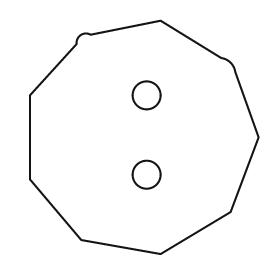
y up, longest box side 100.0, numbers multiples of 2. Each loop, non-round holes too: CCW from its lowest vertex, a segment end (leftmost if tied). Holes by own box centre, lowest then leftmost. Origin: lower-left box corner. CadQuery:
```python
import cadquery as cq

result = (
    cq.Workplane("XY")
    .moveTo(56.0, 0.0)
    .lineTo(86.0, 18.0)
    .lineTo(98.0, 50.0)
    .lineTo(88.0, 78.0)
    .threePointArc((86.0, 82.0), (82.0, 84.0))
    .lineTo(56.0, 100.0)
    .lineTo(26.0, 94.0)
    .threePointArc((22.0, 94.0), (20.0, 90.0))
    .lineTo(0.0, 68.0)
    .lineTo(0.0, 32.0)
    .lineTo(22.0, 6.0)
    .close()
    .moveTo(50.0, 34.0)
    .circle(6.0)
    .moveTo(50.0, 68.0)
    .circle(6.0)
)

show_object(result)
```